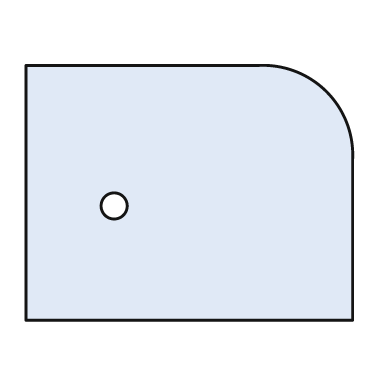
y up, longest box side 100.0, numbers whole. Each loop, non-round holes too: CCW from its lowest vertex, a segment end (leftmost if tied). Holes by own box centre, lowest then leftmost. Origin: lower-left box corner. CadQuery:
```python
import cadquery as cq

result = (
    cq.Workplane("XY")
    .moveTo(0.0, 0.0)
    .lineTo(100.0, 0.0)
    .lineTo(100.0, 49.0)
    .threePointArc((92.0, 70.0), (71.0, 78.0))
    .lineTo(0.0, 78.0)
    .close()
    .moveTo(27.0, 35.0)
    .circle(4.0)
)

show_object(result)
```